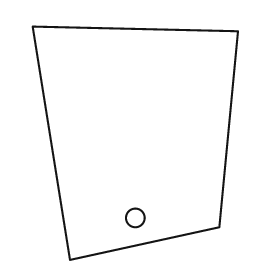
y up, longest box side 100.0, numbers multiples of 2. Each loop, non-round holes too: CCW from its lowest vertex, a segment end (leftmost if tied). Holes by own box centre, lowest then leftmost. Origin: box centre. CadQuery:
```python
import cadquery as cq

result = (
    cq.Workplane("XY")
    .moveTo(-28.0, -50.0)
    .lineTo(36.0, -36.0)
    .lineTo(44.0, 48.0)
    .lineTo(-44.0, 50.0)
    .close()
    .moveTo(0.0, -32.0)
    .circle(4.0)
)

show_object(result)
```